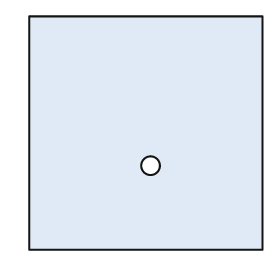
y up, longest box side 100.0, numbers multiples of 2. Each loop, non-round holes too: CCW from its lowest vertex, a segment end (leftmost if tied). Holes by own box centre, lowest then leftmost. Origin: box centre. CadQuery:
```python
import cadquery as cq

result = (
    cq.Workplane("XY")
    .moveTo(-50.0, -50.0)
    .lineTo(50.0, -50.0)
    .lineTo(50.0, 50.0)
    .lineTo(-50.0, 50.0)
    .close()
    .moveTo(2.0, -14.0)
    .circle(4.0)
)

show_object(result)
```